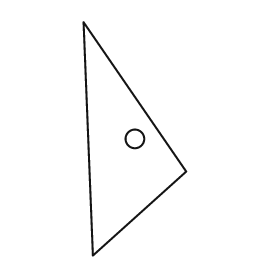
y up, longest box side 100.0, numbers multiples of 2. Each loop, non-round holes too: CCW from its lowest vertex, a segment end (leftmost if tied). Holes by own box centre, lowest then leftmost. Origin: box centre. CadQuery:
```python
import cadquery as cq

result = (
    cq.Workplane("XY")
    .moveTo(-18.0, -50.0)
    .lineTo(22.0, -14.0)
    .lineTo(-22.0, 50.0)
    .close()
    .moveTo(0.0, 0.0)
    .circle(4.0)
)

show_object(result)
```